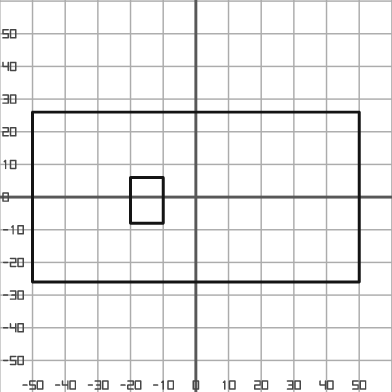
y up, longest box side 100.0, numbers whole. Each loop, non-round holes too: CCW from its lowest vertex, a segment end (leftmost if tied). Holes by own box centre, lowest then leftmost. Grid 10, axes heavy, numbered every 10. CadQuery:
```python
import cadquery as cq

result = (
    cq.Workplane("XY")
    .moveTo(-50.0, -26.0)
    .lineTo(50.0, -26.0)
    .lineTo(50.0, 26.0)
    .lineTo(-50.0, 26.0)
    .close()
    .moveTo(-20.0, -8.0)
    .lineTo(-10.0, -8.0)
    .lineTo(-10.0, 6.0)
    .lineTo(-20.0, 6.0)
    .close()
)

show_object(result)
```